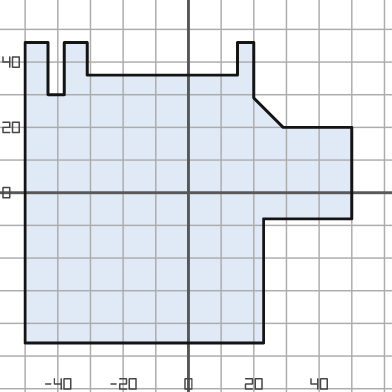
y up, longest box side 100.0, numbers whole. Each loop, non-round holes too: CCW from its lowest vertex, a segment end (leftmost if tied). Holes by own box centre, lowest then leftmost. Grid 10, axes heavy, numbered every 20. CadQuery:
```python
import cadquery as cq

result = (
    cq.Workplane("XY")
    .moveTo(-50.0, -46.0)
    .lineTo(23.0, -46.0)
    .lineTo(23.0, -8.0)
    .lineTo(50.0, -8.0)
    .lineTo(50.0, 20.0)
    .lineTo(29.0, 20.0)
    .lineTo(20.0, 29.0)
    .lineTo(20.0, 46.0)
    .lineTo(15.0, 46.0)
    .lineTo(15.0, 36.0)
    .lineTo(-31.0, 36.0)
    .lineTo(-31.0, 46.0)
    .lineTo(-38.0, 46.0)
    .lineTo(-38.0, 30.0)
    .lineTo(-43.0, 30.0)
    .lineTo(-43.0, 46.0)
    .lineTo(-50.0, 46.0)
    .close()
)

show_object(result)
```